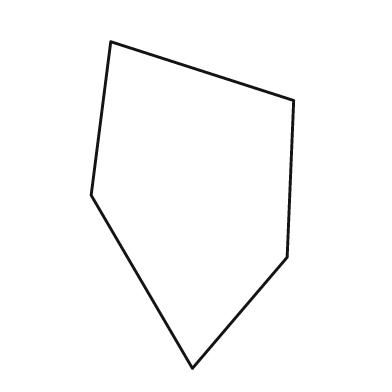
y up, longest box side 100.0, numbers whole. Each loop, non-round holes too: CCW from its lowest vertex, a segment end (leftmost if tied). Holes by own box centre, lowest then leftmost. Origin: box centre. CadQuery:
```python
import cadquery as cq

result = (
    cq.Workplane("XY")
    .moveTo(0.0, -50.0)
    .lineTo(29.0, -16.0)
    .lineTo(31.0, 32.0)
    .lineTo(-25.0, 50.0)
    .lineTo(-31.0, 3.0)
    .close()
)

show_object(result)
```